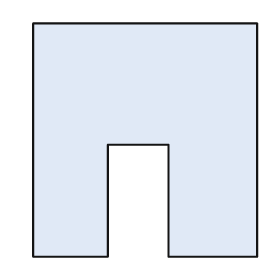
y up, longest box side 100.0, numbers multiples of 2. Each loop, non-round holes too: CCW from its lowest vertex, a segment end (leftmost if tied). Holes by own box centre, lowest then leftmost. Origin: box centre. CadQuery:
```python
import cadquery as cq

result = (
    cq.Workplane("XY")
    .moveTo(-48.0, -50.0)
    .lineTo(-16.0, -50.0)
    .lineTo(-16.0, -2.0)
    .lineTo(10.0, -2.0)
    .lineTo(10.0, -50.0)
    .lineTo(48.0, -50.0)
    .lineTo(48.0, 50.0)
    .lineTo(-48.0, 50.0)
    .close()
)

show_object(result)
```